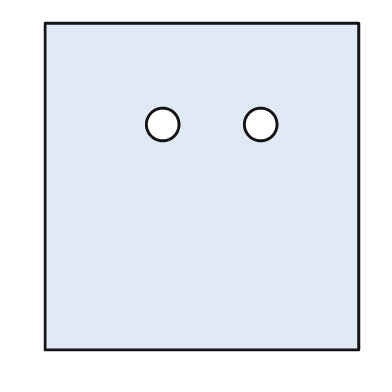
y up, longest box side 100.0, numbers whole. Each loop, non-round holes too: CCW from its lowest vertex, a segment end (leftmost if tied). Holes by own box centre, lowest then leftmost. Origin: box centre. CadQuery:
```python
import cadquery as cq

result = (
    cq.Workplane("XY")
    .moveTo(-48.0, -50.0)
    .lineTo(48.0, -50.0)
    .lineTo(48.0, 50.0)
    .lineTo(-48.0, 50.0)
    .close()
    .moveTo(-12.0, 19.0)
    .circle(5.0)
    .moveTo(18.0, 19.0)
    .circle(5.0)
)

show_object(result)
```